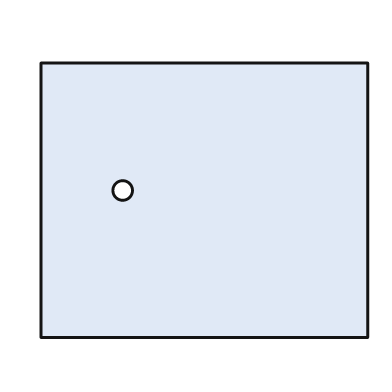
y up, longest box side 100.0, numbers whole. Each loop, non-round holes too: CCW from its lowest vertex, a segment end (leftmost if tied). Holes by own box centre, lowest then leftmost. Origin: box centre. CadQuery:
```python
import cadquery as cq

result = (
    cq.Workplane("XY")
    .moveTo(-50.0, -42.0)
    .lineTo(50.0, -42.0)
    .lineTo(50.0, 42.0)
    .lineTo(-50.0, 42.0)
    .close()
    .moveTo(-25.0, 3.0)
    .circle(3.0)
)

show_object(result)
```